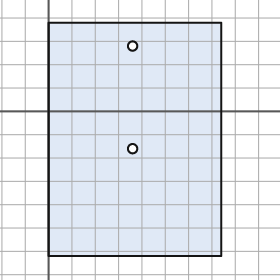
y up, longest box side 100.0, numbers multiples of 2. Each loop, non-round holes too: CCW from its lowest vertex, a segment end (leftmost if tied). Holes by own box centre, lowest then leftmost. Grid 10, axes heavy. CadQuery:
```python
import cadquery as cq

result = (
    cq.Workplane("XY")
    .moveTo(0.0, -62.0)
    .lineTo(74.0, -62.0)
    .lineTo(74.0, 38.0)
    .lineTo(0.0, 38.0)
    .close()
    .moveTo(36.0, -16.0)
    .circle(2.0)
    .moveTo(36.0, 28.0)
    .circle(2.0)
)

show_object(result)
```